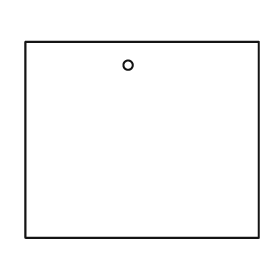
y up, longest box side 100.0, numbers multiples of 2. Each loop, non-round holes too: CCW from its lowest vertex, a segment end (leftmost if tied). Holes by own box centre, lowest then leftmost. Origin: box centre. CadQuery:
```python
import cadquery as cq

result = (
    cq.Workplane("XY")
    .moveTo(-50.0, -42.0)
    .lineTo(50.0, -42.0)
    .lineTo(50.0, 42.0)
    .lineTo(-50.0, 42.0)
    .close()
    .moveTo(-6.0, 32.0)
    .circle(2.0)
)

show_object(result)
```